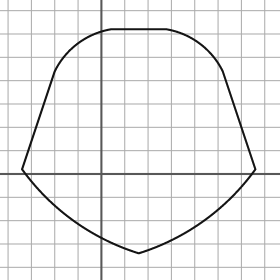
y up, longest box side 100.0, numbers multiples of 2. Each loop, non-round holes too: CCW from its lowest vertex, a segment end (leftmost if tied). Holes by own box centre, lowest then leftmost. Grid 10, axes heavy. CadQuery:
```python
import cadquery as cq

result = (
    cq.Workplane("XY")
    .moveTo(16.0, -34.0)
    .threePointArc((44.0, -20.0), (66.0, 2.0))
    .lineTo(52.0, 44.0)
    .threePointArc((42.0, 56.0), (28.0, 62.0))
    .lineTo(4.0, 62.0)
    .threePointArc((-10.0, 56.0), (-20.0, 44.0))
    .lineTo(-34.0, 2.0)
    .threePointArc((-12.0, -20.0), (16.0, -34.0))
    .close()
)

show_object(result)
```